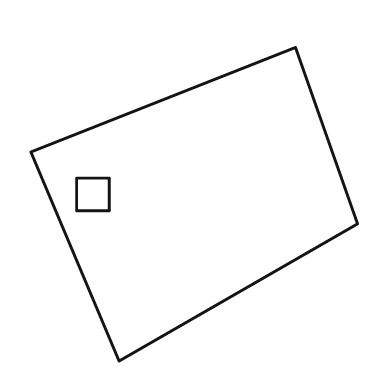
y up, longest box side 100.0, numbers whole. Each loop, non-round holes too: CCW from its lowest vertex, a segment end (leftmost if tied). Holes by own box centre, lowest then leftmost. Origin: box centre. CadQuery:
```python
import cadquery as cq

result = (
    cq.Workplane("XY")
    .moveTo(-23.0, -48.0)
    .lineTo(50.0, -6.0)
    .lineTo(31.0, 48.0)
    .lineTo(-50.0, 16.0)
    .close()
    .moveTo(-36.0, -2.0)
    .lineTo(-26.0, -2.0)
    .lineTo(-26.0, 8.0)
    .lineTo(-36.0, 8.0)
    .close()
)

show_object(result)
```